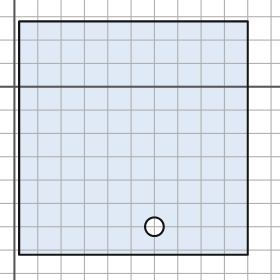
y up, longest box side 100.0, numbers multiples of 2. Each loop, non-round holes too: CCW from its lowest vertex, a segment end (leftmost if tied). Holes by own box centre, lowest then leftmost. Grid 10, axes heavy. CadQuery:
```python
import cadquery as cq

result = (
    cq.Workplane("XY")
    .moveTo(2.0, -72.0)
    .lineTo(100.0, -72.0)
    .lineTo(100.0, 28.0)
    .lineTo(2.0, 28.0)
    .close()
    .moveTo(60.0, -60.0)
    .circle(4.0)
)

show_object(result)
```